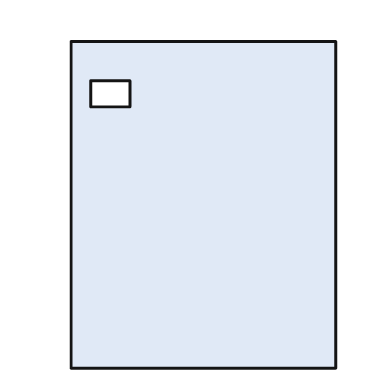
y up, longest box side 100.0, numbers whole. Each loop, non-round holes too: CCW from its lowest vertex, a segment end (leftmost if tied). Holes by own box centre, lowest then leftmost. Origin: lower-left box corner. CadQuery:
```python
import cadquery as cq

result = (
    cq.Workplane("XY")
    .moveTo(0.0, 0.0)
    .lineTo(81.0, 0.0)
    .lineTo(81.0, 100.0)
    .lineTo(0.0, 100.0)
    .close()
    .moveTo(6.0, 80.0)
    .lineTo(18.0, 80.0)
    .lineTo(18.0, 88.0)
    .lineTo(6.0, 88.0)
    .close()
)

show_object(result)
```